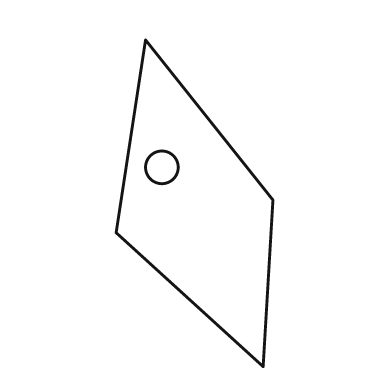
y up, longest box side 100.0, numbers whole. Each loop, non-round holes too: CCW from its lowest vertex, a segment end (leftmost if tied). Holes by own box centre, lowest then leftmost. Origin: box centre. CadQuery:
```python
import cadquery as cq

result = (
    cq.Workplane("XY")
    .moveTo(21.0, -50.0)
    .lineTo(24.0, 1.0)
    .lineTo(-15.0, 50.0)
    .lineTo(-24.0, -9.0)
    .close()
    .moveTo(-10.0, 11.0)
    .circle(5.0)
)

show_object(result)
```